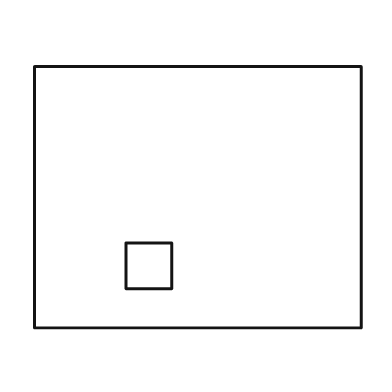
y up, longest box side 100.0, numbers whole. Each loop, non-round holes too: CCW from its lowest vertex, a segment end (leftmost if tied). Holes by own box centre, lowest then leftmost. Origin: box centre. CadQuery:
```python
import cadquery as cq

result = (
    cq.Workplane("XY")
    .moveTo(-50.0, -40.0)
    .lineTo(50.0, -40.0)
    .lineTo(50.0, 40.0)
    .lineTo(-50.0, 40.0)
    .close()
    .moveTo(-22.0, -28.0)
    .lineTo(-8.0, -28.0)
    .lineTo(-8.0, -14.0)
    .lineTo(-22.0, -14.0)
    .close()
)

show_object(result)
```